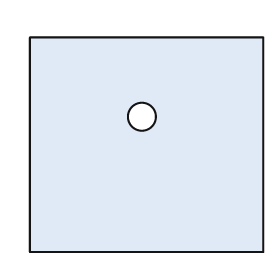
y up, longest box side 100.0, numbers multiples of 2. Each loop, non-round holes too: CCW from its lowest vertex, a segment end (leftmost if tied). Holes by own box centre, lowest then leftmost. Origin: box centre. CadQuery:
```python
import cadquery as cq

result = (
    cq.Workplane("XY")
    .moveTo(-50.0, -46.0)
    .lineTo(50.0, -46.0)
    .lineTo(50.0, 46.0)
    .lineTo(-50.0, 46.0)
    .close()
    .moveTo(-2.0, 12.0)
    .circle(6.0)
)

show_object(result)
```